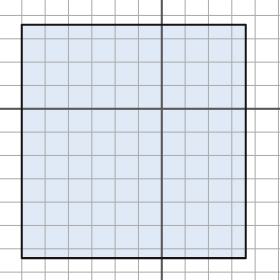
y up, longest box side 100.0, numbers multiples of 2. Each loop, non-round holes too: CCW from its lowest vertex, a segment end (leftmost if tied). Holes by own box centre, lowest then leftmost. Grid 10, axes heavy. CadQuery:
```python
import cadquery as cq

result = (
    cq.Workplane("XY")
    .moveTo(-60.0, -64.0)
    .lineTo(36.0, -64.0)
    .lineTo(36.0, 36.0)
    .lineTo(-60.0, 36.0)
    .close()
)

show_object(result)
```